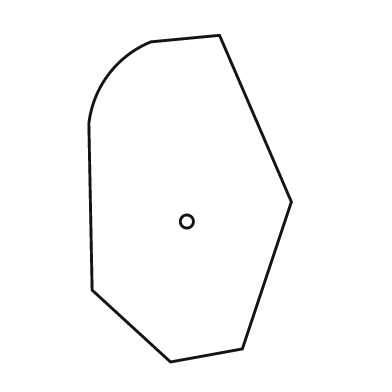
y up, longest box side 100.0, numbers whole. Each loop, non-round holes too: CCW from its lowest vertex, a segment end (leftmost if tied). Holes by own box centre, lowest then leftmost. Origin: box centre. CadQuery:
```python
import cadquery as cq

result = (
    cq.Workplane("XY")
    .moveTo(-6.0, -50.0)
    .lineTo(16.0, -46.0)
    .lineTo(31.0, -1.0)
    .lineTo(9.0, 50.0)
    .lineTo(-12.0, 48.0)
    .threePointArc((-25.0, 38.0), (-31.0, 23.0))
    .lineTo(-30.0, -28.0)
    .close()
    .moveTo(-1.0, -7.0)
    .circle(2.0)
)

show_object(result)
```